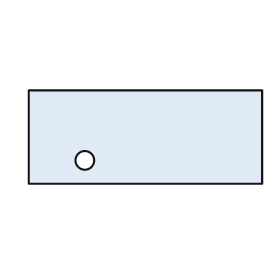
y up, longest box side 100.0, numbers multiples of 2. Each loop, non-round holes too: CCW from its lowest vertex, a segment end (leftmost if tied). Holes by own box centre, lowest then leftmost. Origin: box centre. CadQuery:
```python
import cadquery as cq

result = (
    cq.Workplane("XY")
    .moveTo(-50.0, -20.0)
    .lineTo(50.0, -20.0)
    .lineTo(50.0, 20.0)
    .lineTo(-50.0, 20.0)
    .close()
    .moveTo(-26.0, -10.0)
    .circle(4.0)
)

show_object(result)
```